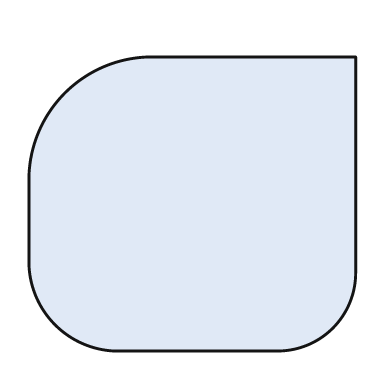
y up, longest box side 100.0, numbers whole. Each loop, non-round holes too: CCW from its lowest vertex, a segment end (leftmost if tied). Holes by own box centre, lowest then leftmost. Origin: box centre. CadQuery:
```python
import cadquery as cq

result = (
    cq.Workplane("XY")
    .moveTo(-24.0, -45.0)
    .lineTo(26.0, -45.0)
    .threePointArc((43.0, -38.0), (50.0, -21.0))
    .lineTo(50.0, 45.0)
    .lineTo(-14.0, 45.0)
    .threePointArc((-39.0, 34.0), (-50.0, 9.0))
    .lineTo(-50.0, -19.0)
    .threePointArc((-42.0, -37.0), (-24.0, -45.0))
    .close()
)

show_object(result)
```